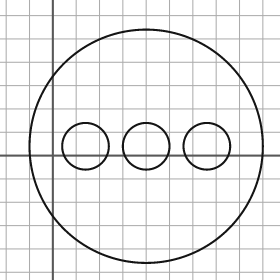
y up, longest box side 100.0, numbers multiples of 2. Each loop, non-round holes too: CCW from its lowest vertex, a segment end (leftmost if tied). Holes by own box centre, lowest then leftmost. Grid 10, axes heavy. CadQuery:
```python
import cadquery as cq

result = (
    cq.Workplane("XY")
    .moveTo(40.0, 4.0)
    .circle(50.0)
    .moveTo(14.0, 4.0)
    .circle(10.0)
    .moveTo(40.0, 4.0)
    .circle(10.0)
    .moveTo(66.0, 4.0)
    .circle(10.0)
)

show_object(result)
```